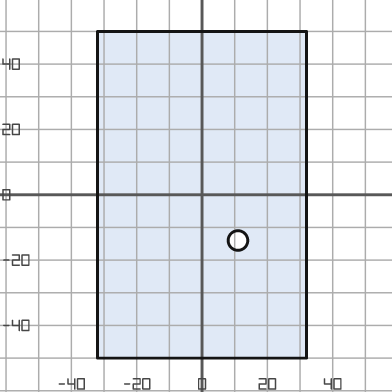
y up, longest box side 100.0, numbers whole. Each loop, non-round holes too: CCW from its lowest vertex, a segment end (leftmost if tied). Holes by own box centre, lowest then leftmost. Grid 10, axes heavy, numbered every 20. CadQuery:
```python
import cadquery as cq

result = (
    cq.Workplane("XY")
    .moveTo(-32.0, -50.0)
    .lineTo(32.0, -50.0)
    .lineTo(32.0, 50.0)
    .lineTo(-32.0, 50.0)
    .close()
    .moveTo(11.0, -14.0)
    .circle(3.0)
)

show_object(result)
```